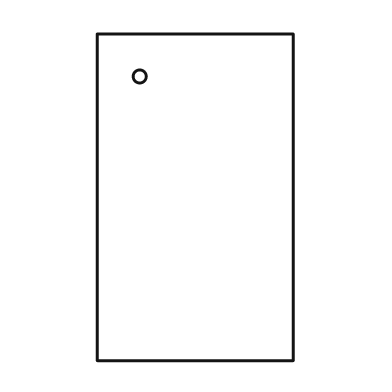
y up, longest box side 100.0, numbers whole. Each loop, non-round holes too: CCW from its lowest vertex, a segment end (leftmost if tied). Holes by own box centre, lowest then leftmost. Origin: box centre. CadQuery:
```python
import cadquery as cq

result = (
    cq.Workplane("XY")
    .moveTo(-30.0, -50.0)
    .lineTo(30.0, -50.0)
    .lineTo(30.0, 50.0)
    .lineTo(-30.0, 50.0)
    .close()
    .moveTo(-17.0, 37.0)
    .circle(2.0)
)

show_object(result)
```